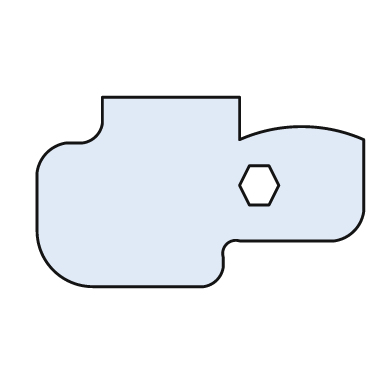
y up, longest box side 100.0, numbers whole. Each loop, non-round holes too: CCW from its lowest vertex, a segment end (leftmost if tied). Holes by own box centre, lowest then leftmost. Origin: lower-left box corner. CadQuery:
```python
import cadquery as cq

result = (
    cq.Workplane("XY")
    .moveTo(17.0, 0.0)
    .lineTo(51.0, 0.0)
    .threePointArc((55.0, 2.0), (57.0, 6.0))
    .lineTo(57.0, 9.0)
    .threePointArc((58.0, 13.0), (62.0, 14.0))
    .lineTo(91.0, 14.0)
    .threePointArc((97.0, 17.0), (100.0, 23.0))
    .lineTo(100.0, 45.0)
    .threePointArc((81.0, 49.0), (62.0, 45.0))
    .lineTo(62.0, 58.0)
    .lineTo(20.0, 58.0)
    .lineTo(20.0, 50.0)
    .threePointArc((18.0, 46.0), (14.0, 44.0))
    .lineTo(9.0, 44.0)
    .threePointArc((3.0, 41.0), (0.0, 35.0))
    .lineTo(0.0, 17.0)
    .threePointArc((5.0, 5.0), (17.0, 0.0))
    .close()
    .moveTo(65.0, 25.0)
    .lineTo(71.0, 25.0)
    .lineTo(74.0, 31.0)
    .lineTo(71.0, 37.0)
    .lineTo(65.0, 37.0)
    .lineTo(62.0, 31.0)
    .close()
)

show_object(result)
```